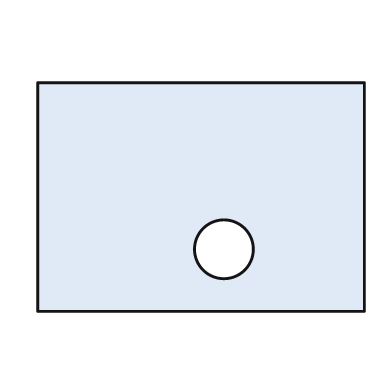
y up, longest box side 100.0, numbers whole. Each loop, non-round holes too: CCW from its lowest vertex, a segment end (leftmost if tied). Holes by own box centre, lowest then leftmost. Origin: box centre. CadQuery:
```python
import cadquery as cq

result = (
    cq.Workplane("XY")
    .moveTo(-50.0, -35.0)
    .lineTo(50.0, -35.0)
    .lineTo(50.0, 35.0)
    .lineTo(-50.0, 35.0)
    .close()
    .moveTo(7.0, -16.0)
    .circle(9.0)
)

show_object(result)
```